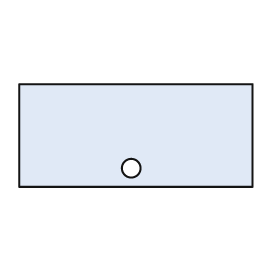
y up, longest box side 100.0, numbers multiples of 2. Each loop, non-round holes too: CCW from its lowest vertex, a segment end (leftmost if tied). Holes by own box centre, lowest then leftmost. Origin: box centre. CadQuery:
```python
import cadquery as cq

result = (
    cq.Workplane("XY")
    .moveTo(-50.0, -22.0)
    .lineTo(50.0, -22.0)
    .lineTo(50.0, 22.0)
    .lineTo(-50.0, 22.0)
    .close()
    .moveTo(-2.0, -14.0)
    .circle(4.0)
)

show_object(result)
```